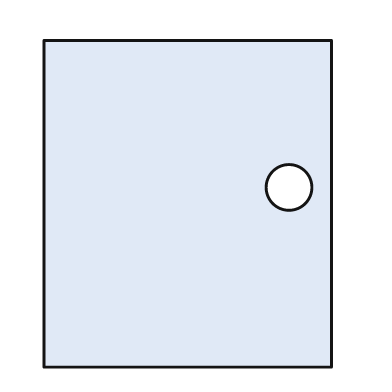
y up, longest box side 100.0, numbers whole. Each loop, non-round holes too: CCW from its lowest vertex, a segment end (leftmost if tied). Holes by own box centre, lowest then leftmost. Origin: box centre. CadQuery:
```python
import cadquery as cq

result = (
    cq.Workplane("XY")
    .moveTo(-44.0, -50.0)
    .lineTo(44.0, -50.0)
    .lineTo(44.0, 50.0)
    .lineTo(-44.0, 50.0)
    .close()
    .moveTo(31.0, 5.0)
    .circle(7.0)
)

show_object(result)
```